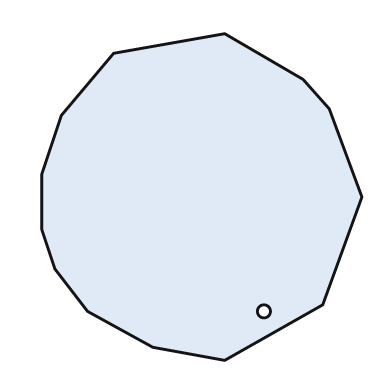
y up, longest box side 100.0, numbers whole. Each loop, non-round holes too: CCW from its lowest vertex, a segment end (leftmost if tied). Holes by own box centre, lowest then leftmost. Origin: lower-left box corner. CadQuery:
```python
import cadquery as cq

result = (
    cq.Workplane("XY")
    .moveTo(56.0, 0.0)
    .lineTo(86.0, 17.0)
    .lineTo(98.0, 50.0)
    .lineTo(88.0, 77.0)
    .lineTo(80.0, 86.0)
    .lineTo(56.0, 100.0)
    .lineTo(22.0, 94.0)
    .lineTo(6.0, 75.0)
    .lineTo(0.0, 57.0)
    .lineTo(0.0, 40.0)
    .lineTo(4.0, 28.0)
    .lineTo(14.0, 15.0)
    .lineTo(34.0, 4.0)
    .close()
    .moveTo(68.0, 15.0)
    .circle(2.0)
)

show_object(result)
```